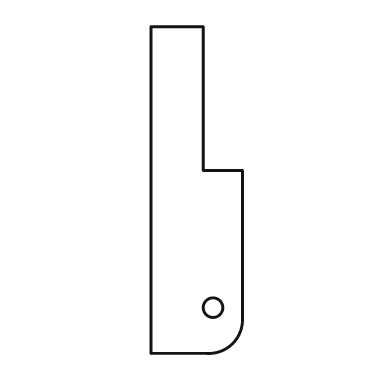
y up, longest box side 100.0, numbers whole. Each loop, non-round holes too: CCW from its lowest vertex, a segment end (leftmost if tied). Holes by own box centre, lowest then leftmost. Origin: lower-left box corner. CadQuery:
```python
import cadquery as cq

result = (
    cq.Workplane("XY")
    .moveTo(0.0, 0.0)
    .lineTo(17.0, 0.0)
    .threePointArc((25.0, 3.0), (28.0, 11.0))
    .lineTo(28.0, 56.0)
    .lineTo(16.0, 56.0)
    .lineTo(16.0, 100.0)
    .lineTo(0.0, 100.0)
    .close()
    .moveTo(19.0, 14.0)
    .circle(3.0)
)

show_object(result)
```